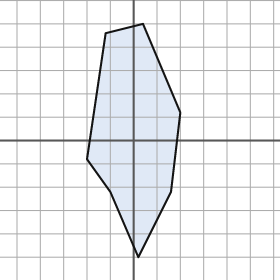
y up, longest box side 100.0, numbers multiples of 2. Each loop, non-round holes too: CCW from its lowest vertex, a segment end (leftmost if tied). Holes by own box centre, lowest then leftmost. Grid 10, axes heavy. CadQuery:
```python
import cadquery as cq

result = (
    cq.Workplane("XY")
    .moveTo(2.0, -50.0)
    .lineTo(16.0, -22.0)
    .lineTo(20.0, 12.0)
    .lineTo(4.0, 50.0)
    .lineTo(-12.0, 46.0)
    .lineTo(-20.0, -8.0)
    .lineTo(-10.0, -22.0)
    .close()
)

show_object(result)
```